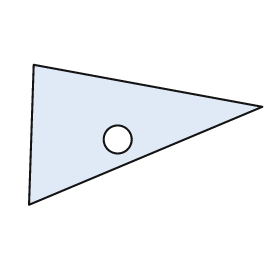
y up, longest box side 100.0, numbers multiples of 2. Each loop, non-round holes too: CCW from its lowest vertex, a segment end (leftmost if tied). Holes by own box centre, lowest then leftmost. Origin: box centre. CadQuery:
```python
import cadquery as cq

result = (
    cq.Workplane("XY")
    .moveTo(-50.0, -30.0)
    .lineTo(50.0, 12.0)
    .lineTo(-48.0, 30.0)
    .close()
    .moveTo(-12.0, -2.0)
    .circle(6.0)
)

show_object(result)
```